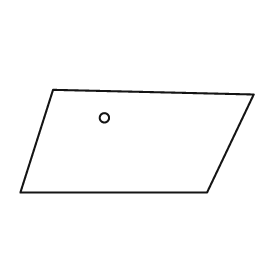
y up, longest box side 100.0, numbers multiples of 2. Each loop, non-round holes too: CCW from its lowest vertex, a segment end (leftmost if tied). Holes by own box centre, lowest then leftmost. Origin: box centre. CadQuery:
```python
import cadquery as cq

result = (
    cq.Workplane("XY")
    .moveTo(-50.0, -22.0)
    .lineTo(30.0, -22.0)
    .lineTo(50.0, 20.0)
    .lineTo(-36.0, 22.0)
    .close()
    .moveTo(-14.0, 10.0)
    .circle(2.0)
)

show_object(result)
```